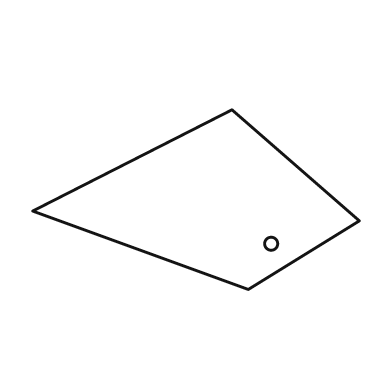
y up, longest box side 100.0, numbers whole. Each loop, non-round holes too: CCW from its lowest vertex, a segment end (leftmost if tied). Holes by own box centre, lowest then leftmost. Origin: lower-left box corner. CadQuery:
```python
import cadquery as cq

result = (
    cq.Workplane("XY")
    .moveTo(66.0, 0.0)
    .lineTo(100.0, 21.0)
    .lineTo(61.0, 55.0)
    .lineTo(0.0, 24.0)
    .close()
    .moveTo(73.0, 14.0)
    .circle(2.0)
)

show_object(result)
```